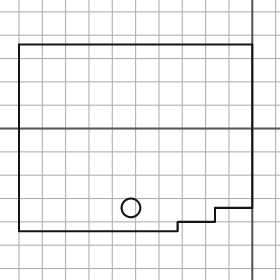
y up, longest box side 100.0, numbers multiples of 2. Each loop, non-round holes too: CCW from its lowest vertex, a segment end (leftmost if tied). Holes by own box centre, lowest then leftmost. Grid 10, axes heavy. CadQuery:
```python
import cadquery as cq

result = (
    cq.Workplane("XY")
    .moveTo(-100.0, -44.0)
    .lineTo(-32.0, -44.0)
    .lineTo(-32.0, -40.0)
    .lineTo(-16.0, -40.0)
    .lineTo(-16.0, -34.0)
    .lineTo(0.0, -34.0)
    .lineTo(0.0, 36.0)
    .lineTo(-100.0, 36.0)
    .close()
    .moveTo(-52.0, -34.0)
    .circle(4.0)
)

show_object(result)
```